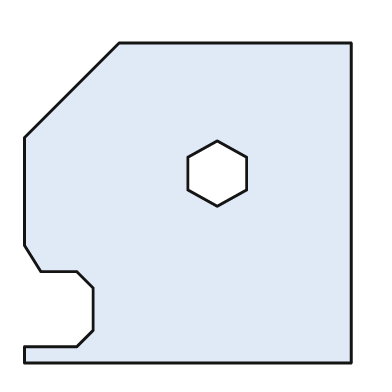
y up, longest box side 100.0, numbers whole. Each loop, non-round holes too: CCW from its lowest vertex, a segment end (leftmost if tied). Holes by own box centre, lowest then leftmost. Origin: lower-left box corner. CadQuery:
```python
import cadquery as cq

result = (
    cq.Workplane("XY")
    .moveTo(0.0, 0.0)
    .lineTo(100.0, 0.0)
    .lineTo(100.0, 98.0)
    .lineTo(29.0, 98.0)
    .lineTo(0.0, 69.0)
    .lineTo(0.0, 36.0)
    .lineTo(5.0, 28.0)
    .lineTo(16.0, 28.0)
    .lineTo(21.0, 23.0)
    .lineTo(21.0, 10.0)
    .lineTo(16.0, 5.0)
    .lineTo(0.0, 5.0)
    .close()
    .moveTo(59.0, 48.0)
    .lineTo(68.0, 53.0)
    .lineTo(68.0, 63.0)
    .lineTo(59.0, 68.0)
    .lineTo(50.0, 63.0)
    .lineTo(50.0, 53.0)
    .close()
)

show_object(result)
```